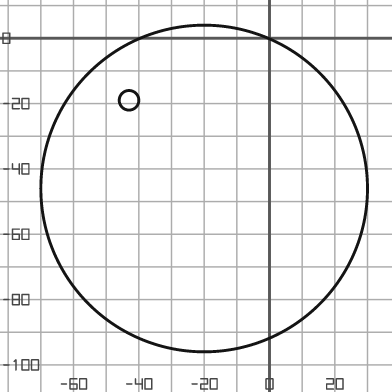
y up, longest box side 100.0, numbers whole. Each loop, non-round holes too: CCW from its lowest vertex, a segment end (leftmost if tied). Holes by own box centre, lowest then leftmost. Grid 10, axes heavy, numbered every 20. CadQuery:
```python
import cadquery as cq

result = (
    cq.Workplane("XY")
    .moveTo(-20.0, -46.0)
    .circle(50.0)
    .moveTo(-43.0, -19.0)
    .circle(3.0)
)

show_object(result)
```